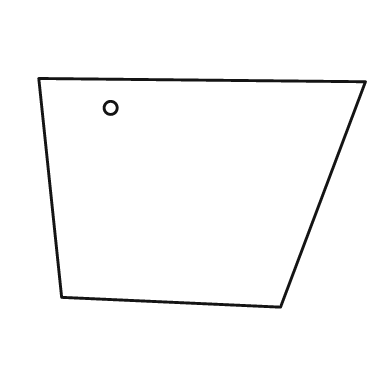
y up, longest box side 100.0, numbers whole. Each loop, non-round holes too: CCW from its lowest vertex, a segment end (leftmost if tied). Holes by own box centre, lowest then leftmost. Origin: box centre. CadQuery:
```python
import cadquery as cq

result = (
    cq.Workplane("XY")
    .moveTo(24.0, -35.0)
    .lineTo(50.0, 34.0)
    .lineTo(-50.0, 35.0)
    .lineTo(-43.0, -32.0)
    .close()
    .moveTo(-28.0, 26.0)
    .circle(2.0)
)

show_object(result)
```